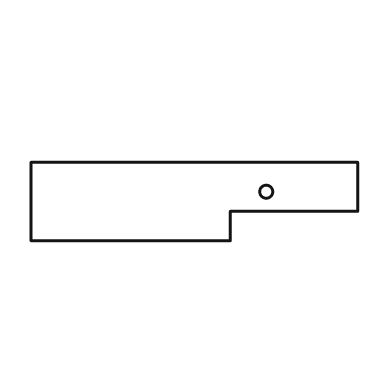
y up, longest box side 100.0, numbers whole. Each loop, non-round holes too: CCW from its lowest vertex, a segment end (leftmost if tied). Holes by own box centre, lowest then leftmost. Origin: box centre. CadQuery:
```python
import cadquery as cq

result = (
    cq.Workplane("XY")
    .moveTo(-50.0, -12.0)
    .lineTo(11.0, -12.0)
    .lineTo(11.0, -3.0)
    .lineTo(50.0, -3.0)
    .lineTo(50.0, 12.0)
    .lineTo(-50.0, 12.0)
    .close()
    .moveTo(22.0, 3.0)
    .circle(2.0)
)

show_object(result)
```